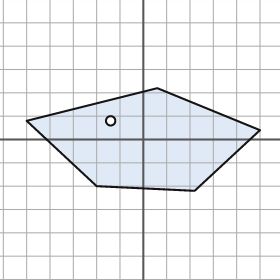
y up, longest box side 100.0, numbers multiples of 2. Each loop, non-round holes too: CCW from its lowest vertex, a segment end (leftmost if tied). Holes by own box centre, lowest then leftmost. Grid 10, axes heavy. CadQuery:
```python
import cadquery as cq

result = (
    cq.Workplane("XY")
    .moveTo(22.0, -22.0)
    .lineTo(50.0, 4.0)
    .lineTo(6.0, 22.0)
    .lineTo(-50.0, 8.0)
    .lineTo(-20.0, -20.0)
    .close()
    .moveTo(-14.0, 8.0)
    .circle(2.0)
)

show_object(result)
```